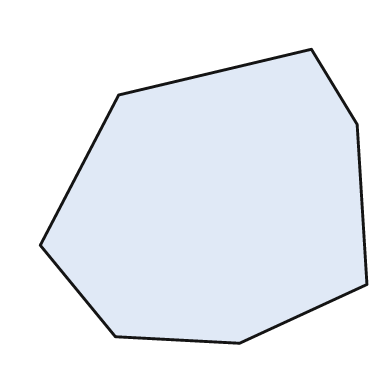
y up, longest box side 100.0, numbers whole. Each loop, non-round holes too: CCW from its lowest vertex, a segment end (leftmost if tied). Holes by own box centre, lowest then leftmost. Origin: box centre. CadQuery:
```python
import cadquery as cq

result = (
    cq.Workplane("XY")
    .moveTo(11.0, -45.0)
    .lineTo(50.0, -27.0)
    .lineTo(47.0, 22.0)
    .lineTo(33.0, 45.0)
    .lineTo(-26.0, 31.0)
    .lineTo(-50.0, -15.0)
    .lineTo(-27.0, -43.0)
    .close()
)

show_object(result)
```